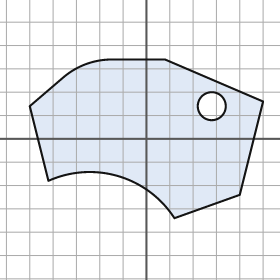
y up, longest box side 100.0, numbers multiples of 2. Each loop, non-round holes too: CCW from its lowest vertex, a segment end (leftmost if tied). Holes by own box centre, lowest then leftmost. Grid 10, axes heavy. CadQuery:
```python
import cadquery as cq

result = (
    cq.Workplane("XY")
    .moveTo(12.0, -34.0)
    .lineTo(40.0, -24.0)
    .lineTo(50.0, 16.0)
    .lineTo(8.0, 34.0)
    .lineTo(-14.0, 34.0)
    .threePointArc((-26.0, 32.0), (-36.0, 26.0))
    .lineTo(-50.0, 14.0)
    .lineTo(-42.0, -18.0)
    .threePointArc((-12.0, -16.0), (12.0, -34.0))
    .close()
    .moveTo(28.0, 14.0)
    .circle(6.0)
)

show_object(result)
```